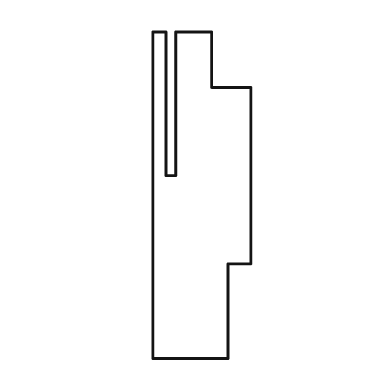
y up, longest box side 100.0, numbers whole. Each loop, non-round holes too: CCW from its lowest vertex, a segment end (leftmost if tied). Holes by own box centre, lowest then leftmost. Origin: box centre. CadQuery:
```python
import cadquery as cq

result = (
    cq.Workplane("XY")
    .moveTo(-15.0, -50.0)
    .lineTo(8.0, -50.0)
    .lineTo(8.0, -21.0)
    .lineTo(15.0, -21.0)
    .lineTo(15.0, 33.0)
    .lineTo(3.0, 33.0)
    .lineTo(3.0, 50.0)
    .lineTo(-8.0, 50.0)
    .lineTo(-8.0, 6.0)
    .lineTo(-11.0, 6.0)
    .lineTo(-11.0, 50.0)
    .lineTo(-15.0, 50.0)
    .close()
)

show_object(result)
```